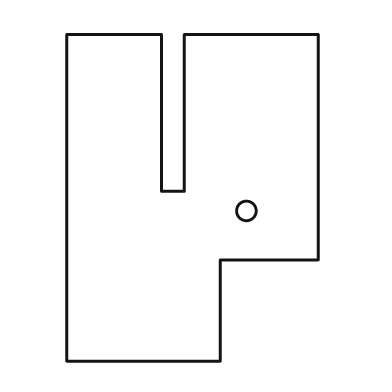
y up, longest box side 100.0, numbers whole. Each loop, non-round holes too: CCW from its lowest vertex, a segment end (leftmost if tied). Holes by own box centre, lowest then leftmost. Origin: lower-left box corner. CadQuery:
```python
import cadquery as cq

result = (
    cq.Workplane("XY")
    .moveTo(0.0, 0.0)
    .lineTo(47.0, 0.0)
    .lineTo(47.0, 31.0)
    .lineTo(77.0, 31.0)
    .lineTo(77.0, 100.0)
    .lineTo(36.0, 100.0)
    .lineTo(36.0, 52.0)
    .lineTo(29.0, 52.0)
    .lineTo(29.0, 100.0)
    .lineTo(0.0, 100.0)
    .close()
    .moveTo(55.0, 46.0)
    .circle(3.0)
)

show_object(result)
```